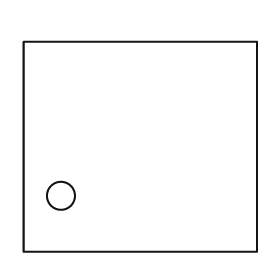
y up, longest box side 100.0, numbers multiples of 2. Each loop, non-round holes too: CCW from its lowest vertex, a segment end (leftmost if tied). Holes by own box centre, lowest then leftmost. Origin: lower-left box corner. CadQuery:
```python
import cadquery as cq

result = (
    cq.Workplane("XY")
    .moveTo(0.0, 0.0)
    .lineTo(100.0, 0.0)
    .lineTo(100.0, 90.0)
    .lineTo(0.0, 90.0)
    .close()
    .moveTo(16.0, 24.0)
    .circle(6.0)
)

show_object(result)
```